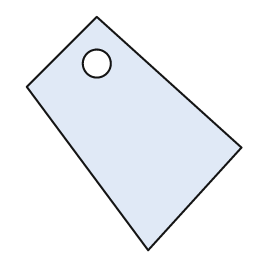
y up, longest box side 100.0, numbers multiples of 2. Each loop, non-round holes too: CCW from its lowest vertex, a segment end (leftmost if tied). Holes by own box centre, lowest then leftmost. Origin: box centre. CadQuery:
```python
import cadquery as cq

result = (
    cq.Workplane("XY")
    .moveTo(6.0, -50.0)
    .lineTo(46.0, -6.0)
    .lineTo(-16.0, 50.0)
    .lineTo(-46.0, 20.0)
    .close()
    .moveTo(-16.0, 30.0)
    .circle(6.0)
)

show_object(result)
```